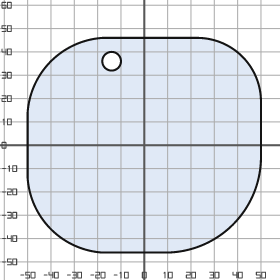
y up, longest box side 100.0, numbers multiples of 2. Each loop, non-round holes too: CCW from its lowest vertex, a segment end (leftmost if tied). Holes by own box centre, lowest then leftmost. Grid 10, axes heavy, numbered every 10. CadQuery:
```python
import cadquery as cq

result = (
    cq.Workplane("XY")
    .moveTo(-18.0, -46.0)
    .lineTo(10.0, -46.0)
    .threePointArc((38.0, -34.0), (50.0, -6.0))
    .lineTo(50.0, 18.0)
    .threePointArc((42.0, 38.0), (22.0, 46.0))
    .lineTo(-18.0, 46.0)
    .threePointArc((-40.0, 36.0), (-50.0, 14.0))
    .lineTo(-50.0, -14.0)
    .threePointArc((-40.0, -36.0), (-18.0, -46.0))
    .close()
    .moveTo(-14.0, 36.0)
    .circle(4.0)
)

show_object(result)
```